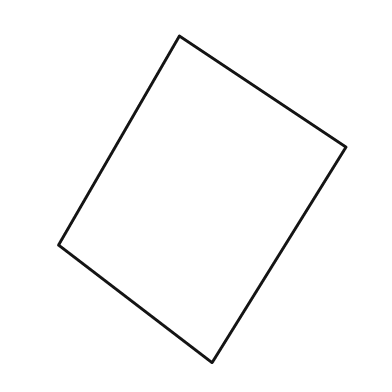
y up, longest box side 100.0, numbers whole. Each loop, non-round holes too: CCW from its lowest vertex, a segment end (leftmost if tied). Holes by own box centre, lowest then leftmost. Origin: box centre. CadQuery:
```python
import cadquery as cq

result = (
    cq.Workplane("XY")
    .moveTo(3.0, -50.0)
    .lineTo(44.0, 16.0)
    .lineTo(-7.0, 50.0)
    .lineTo(-44.0, -14.0)
    .close()
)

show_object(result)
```